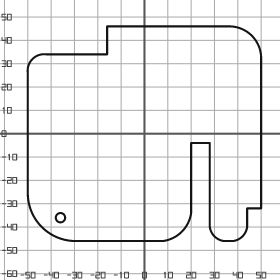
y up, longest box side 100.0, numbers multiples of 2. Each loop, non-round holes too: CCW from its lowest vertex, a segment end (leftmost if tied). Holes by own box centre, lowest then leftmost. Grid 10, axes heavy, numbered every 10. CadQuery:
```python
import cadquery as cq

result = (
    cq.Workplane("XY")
    .moveTo(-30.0, -46.0)
    .lineTo(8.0, -46.0)
    .threePointArc((16.0, -42.0), (20.0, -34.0))
    .lineTo(20.0, -4.0)
    .lineTo(28.0, -4.0)
    .lineTo(28.0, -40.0)
    .threePointArc((30.0, -44.0), (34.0, -46.0))
    .lineTo(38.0, -46.0)
    .threePointArc((42.0, -44.0), (44.0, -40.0))
    .lineTo(44.0, -32.0)
    .lineTo(50.0, -32.0)
    .lineTo(50.0, 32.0)
    .threePointArc((46.0, 42.0), (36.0, 46.0))
    .lineTo(-16.0, 46.0)
    .lineTo(-16.0, 34.0)
    .lineTo(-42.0, 34.0)
    .threePointArc((-48.0, 32.0), (-50.0, 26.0))
    .lineTo(-50.0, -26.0)
    .threePointArc((-44.0, -40.0), (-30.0, -46.0))
    .close()
    .moveTo(-36.0, -36.0)
    .circle(2.0)
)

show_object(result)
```